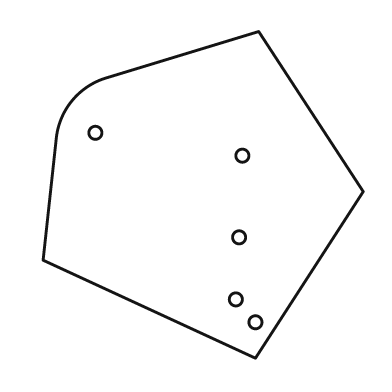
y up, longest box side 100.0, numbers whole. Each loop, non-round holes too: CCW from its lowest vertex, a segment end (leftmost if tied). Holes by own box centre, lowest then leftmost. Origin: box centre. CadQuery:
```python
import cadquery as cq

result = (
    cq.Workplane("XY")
    .moveTo(16.0, -50.0)
    .lineTo(49.0, 1.0)
    .lineTo(17.0, 50.0)
    .lineTo(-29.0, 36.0)
    .threePointArc((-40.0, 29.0), (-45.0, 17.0))
    .lineTo(-49.0, -20.0)
    .close()
    .moveTo(16.0, -39.0)
    .circle(2.0)
    .moveTo(10.0, -32.0)
    .circle(2.0)
    .moveTo(11.0, -13.0)
    .circle(2.0)
    .moveTo(12.0, 12.0)
    .circle(2.0)
    .moveTo(-33.0, 19.0)
    .circle(2.0)
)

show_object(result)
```